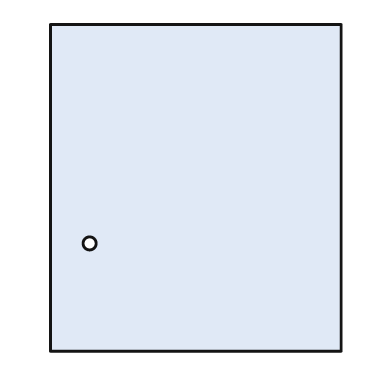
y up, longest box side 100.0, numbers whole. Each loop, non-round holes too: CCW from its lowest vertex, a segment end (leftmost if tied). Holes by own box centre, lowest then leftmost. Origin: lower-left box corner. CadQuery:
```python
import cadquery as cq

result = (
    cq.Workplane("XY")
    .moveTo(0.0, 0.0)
    .lineTo(89.0, 0.0)
    .lineTo(89.0, 100.0)
    .lineTo(0.0, 100.0)
    .close()
    .moveTo(12.0, 33.0)
    .circle(2.0)
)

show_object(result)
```